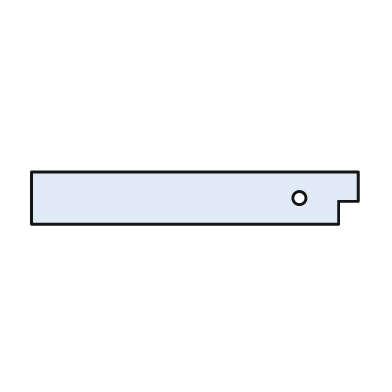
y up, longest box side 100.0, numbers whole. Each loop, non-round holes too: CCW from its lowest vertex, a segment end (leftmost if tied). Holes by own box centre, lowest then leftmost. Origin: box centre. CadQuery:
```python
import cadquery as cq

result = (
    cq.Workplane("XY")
    .moveTo(-50.0, -8.0)
    .lineTo(44.0, -8.0)
    .lineTo(44.0, -1.0)
    .lineTo(50.0, -1.0)
    .lineTo(50.0, 8.0)
    .lineTo(-50.0, 8.0)
    .close()
    .moveTo(32.0, 0.0)
    .circle(2.0)
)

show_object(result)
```